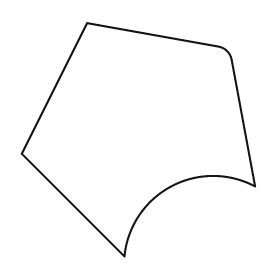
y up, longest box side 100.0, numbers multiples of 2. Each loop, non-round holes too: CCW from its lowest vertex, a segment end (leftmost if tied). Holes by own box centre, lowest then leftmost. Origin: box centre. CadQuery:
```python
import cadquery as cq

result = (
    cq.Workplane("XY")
    .moveTo(-6.0, -50.0)
    .threePointArc((14.0, -20.0), (50.0, -20.0))
    .lineTo(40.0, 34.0)
    .threePointArc((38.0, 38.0), (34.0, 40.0))
    .lineTo(-22.0, 50.0)
    .lineTo(-50.0, -6.0)
    .close()
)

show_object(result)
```